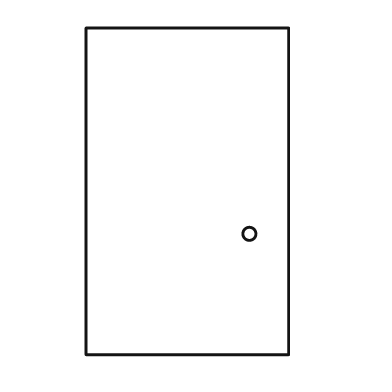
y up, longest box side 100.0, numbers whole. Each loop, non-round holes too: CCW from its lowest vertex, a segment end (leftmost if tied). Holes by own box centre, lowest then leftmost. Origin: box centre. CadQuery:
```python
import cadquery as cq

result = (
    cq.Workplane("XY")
    .moveTo(-31.0, -50.0)
    .lineTo(31.0, -50.0)
    .lineTo(31.0, 50.0)
    .lineTo(-31.0, 50.0)
    .close()
    .moveTo(19.0, -13.0)
    .circle(2.0)
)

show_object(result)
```